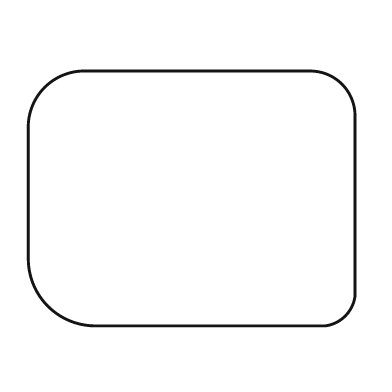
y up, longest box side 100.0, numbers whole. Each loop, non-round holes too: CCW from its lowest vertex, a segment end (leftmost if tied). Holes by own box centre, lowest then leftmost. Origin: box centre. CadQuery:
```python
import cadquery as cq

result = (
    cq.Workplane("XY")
    .moveTo(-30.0, -39.0)
    .lineTo(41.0, -39.0)
    .threePointArc((47.0, -36.0), (50.0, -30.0))
    .lineTo(50.0, 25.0)
    .threePointArc((46.0, 35.0), (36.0, 39.0))
    .lineTo(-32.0, 39.0)
    .threePointArc((-45.0, 34.0), (-50.0, 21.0))
    .lineTo(-50.0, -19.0)
    .threePointArc((-44.0, -33.0), (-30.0, -39.0))
    .close()
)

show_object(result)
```